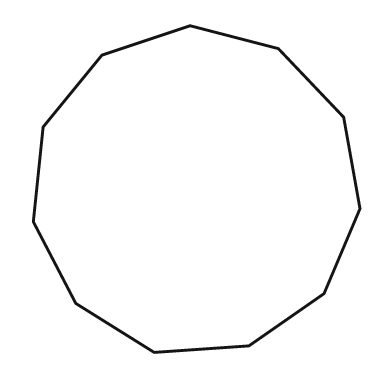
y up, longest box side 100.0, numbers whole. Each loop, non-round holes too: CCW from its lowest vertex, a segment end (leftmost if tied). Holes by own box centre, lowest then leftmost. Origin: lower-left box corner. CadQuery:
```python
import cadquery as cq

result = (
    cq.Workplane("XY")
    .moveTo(37.0, 0.0)
    .lineTo(66.0, 2.0)
    .lineTo(89.0, 18.0)
    .lineTo(100.0, 44.0)
    .lineTo(95.0, 72.0)
    .lineTo(75.0, 93.0)
    .lineTo(48.0, 100.0)
    .lineTo(21.0, 91.0)
    .lineTo(3.0, 69.0)
    .lineTo(0.0, 40.0)
    .lineTo(13.0, 15.0)
    .close()
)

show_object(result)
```